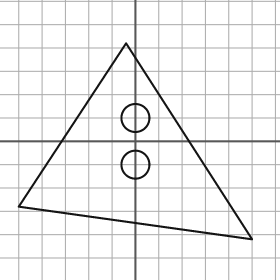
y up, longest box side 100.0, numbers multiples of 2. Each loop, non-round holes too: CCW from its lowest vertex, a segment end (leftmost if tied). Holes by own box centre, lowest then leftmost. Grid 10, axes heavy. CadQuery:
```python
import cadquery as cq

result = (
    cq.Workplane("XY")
    .moveTo(50.0, -42.0)
    .lineTo(-4.0, 42.0)
    .lineTo(-50.0, -28.0)
    .close()
    .moveTo(0.0, -10.0)
    .circle(6.0)
    .moveTo(0.0, 10.0)
    .circle(6.0)
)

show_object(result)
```